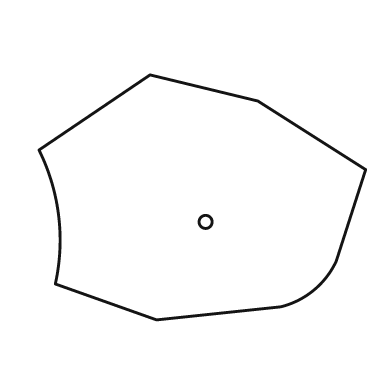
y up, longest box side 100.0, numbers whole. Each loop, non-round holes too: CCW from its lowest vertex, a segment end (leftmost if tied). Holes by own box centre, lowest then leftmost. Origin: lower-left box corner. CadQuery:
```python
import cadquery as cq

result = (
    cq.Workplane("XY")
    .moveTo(36.0, 0.0)
    .lineTo(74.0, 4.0)
    .threePointArc((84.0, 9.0), (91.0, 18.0))
    .lineTo(100.0, 46.0)
    .lineTo(67.0, 67.0)
    .lineTo(34.0, 75.0)
    .lineTo(0.0, 52.0)
    .threePointArc((6.0, 32.0), (5.0, 11.0))
    .close()
    .moveTo(51.0, 30.0)
    .circle(2.0)
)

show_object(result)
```